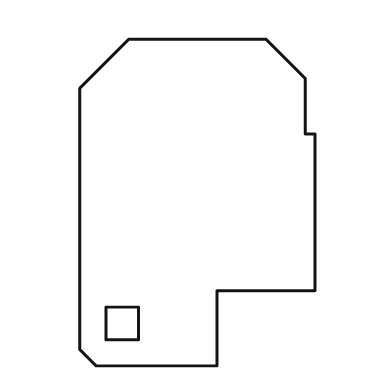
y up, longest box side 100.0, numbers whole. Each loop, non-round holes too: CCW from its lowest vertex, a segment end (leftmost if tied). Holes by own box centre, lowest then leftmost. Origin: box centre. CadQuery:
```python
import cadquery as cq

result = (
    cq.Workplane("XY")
    .moveTo(-31.0, -50.0)
    .lineTo(6.0, -50.0)
    .lineTo(6.0, -27.0)
    .lineTo(36.0, -27.0)
    .lineTo(36.0, 21.0)
    .lineTo(33.0, 21.0)
    .lineTo(33.0, 38.0)
    .lineTo(21.0, 50.0)
    .lineTo(-21.0, 50.0)
    .lineTo(-36.0, 35.0)
    .lineTo(-36.0, -45.0)
    .close()
    .moveTo(-28.0, -42.0)
    .lineTo(-18.0, -42.0)
    .lineTo(-18.0, -32.0)
    .lineTo(-28.0, -32.0)
    .close()
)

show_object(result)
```